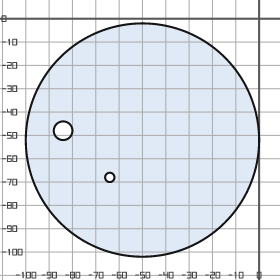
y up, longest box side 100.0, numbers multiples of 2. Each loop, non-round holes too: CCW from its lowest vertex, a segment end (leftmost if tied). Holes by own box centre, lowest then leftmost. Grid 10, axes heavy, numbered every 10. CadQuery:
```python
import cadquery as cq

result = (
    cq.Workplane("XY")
    .moveTo(-50.0, -52.0)
    .circle(50.0)
    .moveTo(-64.0, -68.0)
    .circle(2.0)
    .moveTo(-84.0, -48.0)
    .circle(4.0)
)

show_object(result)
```